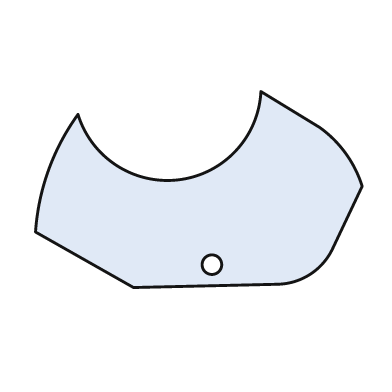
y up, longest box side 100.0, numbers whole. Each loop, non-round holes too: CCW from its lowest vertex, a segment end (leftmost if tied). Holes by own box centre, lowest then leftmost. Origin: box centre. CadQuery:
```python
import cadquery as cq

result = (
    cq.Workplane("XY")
    .moveTo(-20.0, -30.0)
    .lineTo(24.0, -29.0)
    .threePointArc((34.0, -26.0), (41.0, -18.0))
    .lineTo(50.0, 1.0)
    .threePointArc((45.0, 11.0), (37.0, 19.0))
    .lineTo(19.0, 30.0)
    .threePointArc((-6.0, 3.0), (-37.0, 23.0))
    .threePointArc((-46.0, 6.0), (-50.0, -13.0))
    .close()
    .moveTo(4.0, -23.0)
    .circle(3.0)
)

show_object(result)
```